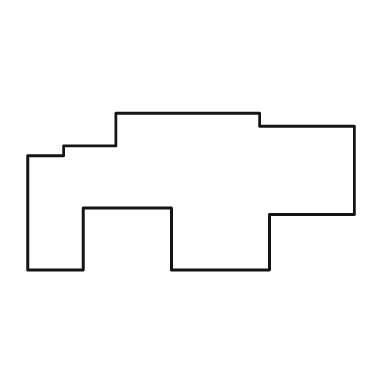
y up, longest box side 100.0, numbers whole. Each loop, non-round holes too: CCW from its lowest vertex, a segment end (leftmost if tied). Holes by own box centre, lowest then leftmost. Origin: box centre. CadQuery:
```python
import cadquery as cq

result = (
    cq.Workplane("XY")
    .moveTo(-50.0, -24.0)
    .lineTo(-33.0, -24.0)
    .lineTo(-33.0, -5.0)
    .lineTo(-6.0, -5.0)
    .lineTo(-6.0, -24.0)
    .lineTo(24.0, -24.0)
    .lineTo(24.0, -7.0)
    .lineTo(50.0, -7.0)
    .lineTo(50.0, 20.0)
    .lineTo(21.0, 20.0)
    .lineTo(21.0, 24.0)
    .lineTo(-23.0, 24.0)
    .lineTo(-23.0, 14.0)
    .lineTo(-39.0, 14.0)
    .lineTo(-39.0, 11.0)
    .lineTo(-50.0, 11.0)
    .close()
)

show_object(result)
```